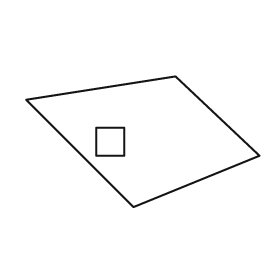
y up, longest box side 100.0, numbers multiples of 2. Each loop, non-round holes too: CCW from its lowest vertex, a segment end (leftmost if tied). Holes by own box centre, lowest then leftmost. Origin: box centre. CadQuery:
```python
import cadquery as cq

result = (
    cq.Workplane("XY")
    .moveTo(-4.0, -28.0)
    .lineTo(50.0, -6.0)
    .lineTo(14.0, 28.0)
    .lineTo(-50.0, 18.0)
    .close()
    .moveTo(-20.0, -6.0)
    .lineTo(-8.0, -6.0)
    .lineTo(-8.0, 6.0)
    .lineTo(-20.0, 6.0)
    .close()
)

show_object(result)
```